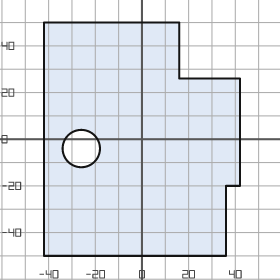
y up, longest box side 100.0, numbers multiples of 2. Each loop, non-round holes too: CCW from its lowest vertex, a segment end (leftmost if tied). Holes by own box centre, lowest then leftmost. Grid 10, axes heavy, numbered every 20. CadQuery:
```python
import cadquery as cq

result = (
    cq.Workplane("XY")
    .moveTo(-42.0, -50.0)
    .lineTo(36.0, -50.0)
    .lineTo(36.0, -20.0)
    .lineTo(42.0, -20.0)
    .lineTo(42.0, 26.0)
    .lineTo(16.0, 26.0)
    .lineTo(16.0, 50.0)
    .lineTo(-42.0, 50.0)
    .close()
    .moveTo(-26.0, -4.0)
    .circle(8.0)
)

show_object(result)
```